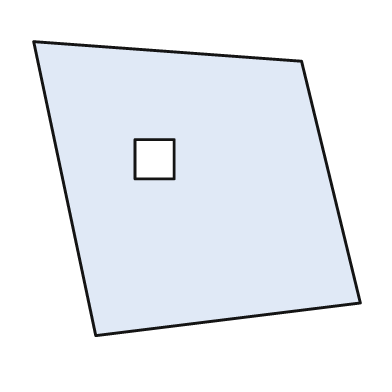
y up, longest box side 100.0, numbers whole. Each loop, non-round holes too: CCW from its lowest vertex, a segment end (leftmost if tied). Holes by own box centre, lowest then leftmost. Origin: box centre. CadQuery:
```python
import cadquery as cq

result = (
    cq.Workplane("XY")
    .moveTo(-31.0, -45.0)
    .lineTo(50.0, -35.0)
    .lineTo(32.0, 39.0)
    .lineTo(-50.0, 45.0)
    .close()
    .moveTo(-19.0, 3.0)
    .lineTo(-7.0, 3.0)
    .lineTo(-7.0, 15.0)
    .lineTo(-19.0, 15.0)
    .close()
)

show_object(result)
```